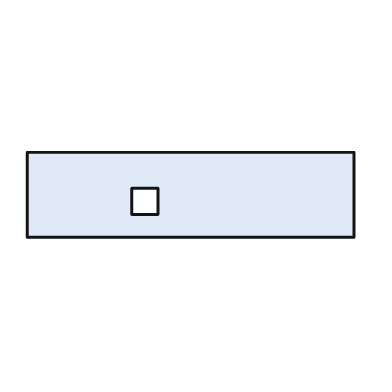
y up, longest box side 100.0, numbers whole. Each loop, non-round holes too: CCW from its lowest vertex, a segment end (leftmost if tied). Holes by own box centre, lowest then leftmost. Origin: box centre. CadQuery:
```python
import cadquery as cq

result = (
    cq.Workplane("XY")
    .moveTo(-50.0, -13.0)
    .lineTo(50.0, -13.0)
    .lineTo(50.0, 13.0)
    .lineTo(-50.0, 13.0)
    .close()
    .moveTo(-18.0, -6.0)
    .lineTo(-10.0, -6.0)
    .lineTo(-10.0, 2.0)
    .lineTo(-18.0, 2.0)
    .close()
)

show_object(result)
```